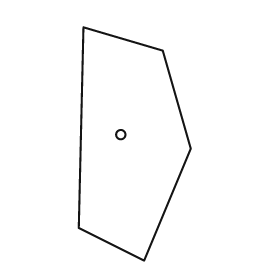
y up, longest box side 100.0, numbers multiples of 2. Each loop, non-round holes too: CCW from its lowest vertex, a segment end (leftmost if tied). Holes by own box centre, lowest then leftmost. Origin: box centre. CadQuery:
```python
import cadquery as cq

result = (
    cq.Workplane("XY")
    .moveTo(4.0, -50.0)
    .lineTo(24.0, -2.0)
    .lineTo(12.0, 40.0)
    .lineTo(-22.0, 50.0)
    .lineTo(-24.0, -36.0)
    .close()
    .moveTo(-6.0, 4.0)
    .circle(2.0)
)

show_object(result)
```